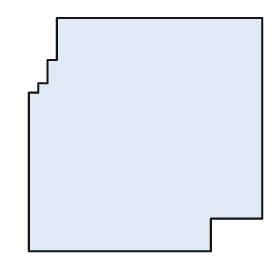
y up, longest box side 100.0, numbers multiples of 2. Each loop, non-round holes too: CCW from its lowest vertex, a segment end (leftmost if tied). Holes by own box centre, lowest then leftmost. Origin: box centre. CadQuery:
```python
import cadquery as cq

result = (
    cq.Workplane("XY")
    .moveTo(-50.0, -50.0)
    .lineTo(28.0, -50.0)
    .lineTo(28.0, -36.0)
    .lineTo(50.0, -36.0)
    .lineTo(50.0, 50.0)
    .lineTo(-38.0, 50.0)
    .lineTo(-38.0, 32.0)
    .lineTo(-42.0, 32.0)
    .lineTo(-42.0, 22.0)
    .lineTo(-46.0, 22.0)
    .lineTo(-46.0, 18.0)
    .lineTo(-50.0, 18.0)
    .close()
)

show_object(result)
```